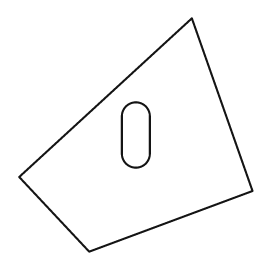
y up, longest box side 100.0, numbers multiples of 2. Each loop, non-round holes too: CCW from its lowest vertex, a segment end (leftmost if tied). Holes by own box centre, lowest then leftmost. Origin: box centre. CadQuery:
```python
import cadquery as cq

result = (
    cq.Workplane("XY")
    .moveTo(-20.0, -50.0)
    .lineTo(50.0, -24.0)
    .lineTo(24.0, 50.0)
    .lineTo(-50.0, -18.0)
    .close()
    .moveTo(-6.0, -8.0)
    .threePointArc((0.0, -14.0), (6.0, -8.0))
    .lineTo(6.0, 8.0)
    .threePointArc((0.0, 14.0), (-6.0, 8.0))
    .close()
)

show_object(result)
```